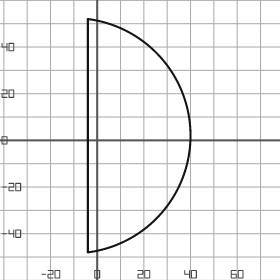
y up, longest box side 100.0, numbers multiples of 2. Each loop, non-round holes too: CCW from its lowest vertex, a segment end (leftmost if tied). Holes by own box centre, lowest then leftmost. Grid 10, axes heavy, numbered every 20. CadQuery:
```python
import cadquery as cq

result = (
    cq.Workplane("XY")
    .moveTo(-4.0, -48.0)
    .threePointArc((40.0, 2.0), (-4.0, 52.0))
    .close()
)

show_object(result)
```